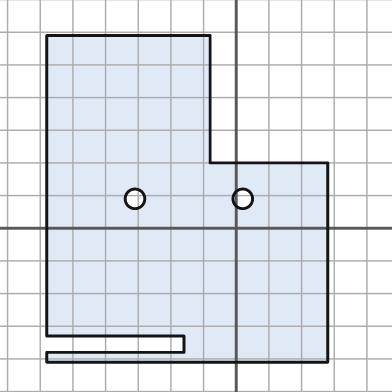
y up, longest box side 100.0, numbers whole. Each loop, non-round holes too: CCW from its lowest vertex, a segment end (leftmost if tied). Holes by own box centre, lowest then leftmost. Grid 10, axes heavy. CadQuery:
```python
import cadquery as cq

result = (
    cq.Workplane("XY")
    .moveTo(-58.0, -41.0)
    .lineTo(28.0, -41.0)
    .lineTo(28.0, 20.0)
    .lineTo(-8.0, 20.0)
    .lineTo(-8.0, 59.0)
    .lineTo(-58.0, 59.0)
    .lineTo(-58.0, -33.0)
    .lineTo(-16.0, -33.0)
    .lineTo(-16.0, -38.0)
    .lineTo(-58.0, -38.0)
    .close()
    .moveTo(-31.0, 9.0)
    .circle(3.0)
    .moveTo(2.0, 9.0)
    .circle(3.0)
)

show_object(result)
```